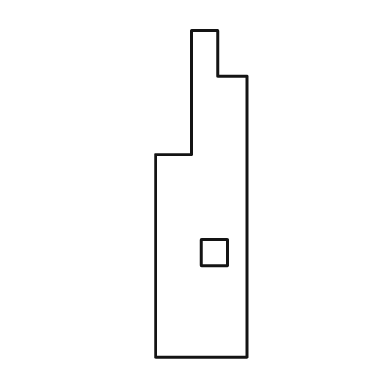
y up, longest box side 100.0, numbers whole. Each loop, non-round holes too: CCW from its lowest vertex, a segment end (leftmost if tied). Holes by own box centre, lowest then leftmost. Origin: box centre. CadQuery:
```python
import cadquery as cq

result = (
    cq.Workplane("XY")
    .moveTo(-14.0, -50.0)
    .lineTo(14.0, -50.0)
    .lineTo(14.0, 36.0)
    .lineTo(5.0, 36.0)
    .lineTo(5.0, 50.0)
    .lineTo(-3.0, 50.0)
    .lineTo(-3.0, 12.0)
    .lineTo(-14.0, 12.0)
    .close()
    .moveTo(0.0, -22.0)
    .lineTo(8.0, -22.0)
    .lineTo(8.0, -14.0)
    .lineTo(0.0, -14.0)
    .close()
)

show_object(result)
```